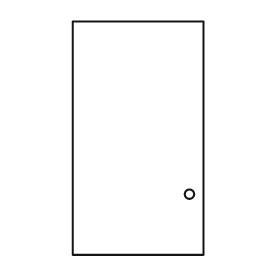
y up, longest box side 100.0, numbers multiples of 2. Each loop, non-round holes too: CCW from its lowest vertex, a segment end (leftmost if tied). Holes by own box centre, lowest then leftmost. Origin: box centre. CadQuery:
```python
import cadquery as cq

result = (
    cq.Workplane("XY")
    .moveTo(-28.0, -50.0)
    .lineTo(28.0, -50.0)
    .lineTo(28.0, 50.0)
    .lineTo(-28.0, 50.0)
    .close()
    .moveTo(22.0, -24.0)
    .circle(2.0)
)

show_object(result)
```